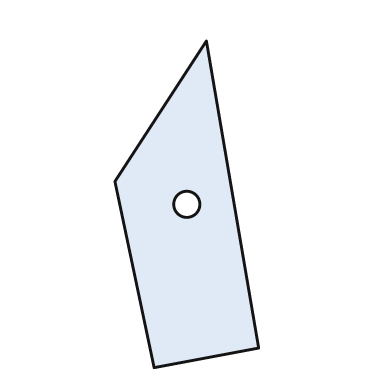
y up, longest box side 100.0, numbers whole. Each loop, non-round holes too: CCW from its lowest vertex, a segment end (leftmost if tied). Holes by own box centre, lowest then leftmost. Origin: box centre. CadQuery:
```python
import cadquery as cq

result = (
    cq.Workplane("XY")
    .moveTo(-10.0, -50.0)
    .lineTo(22.0, -44.0)
    .lineTo(6.0, 50.0)
    .lineTo(-22.0, 7.0)
    .close()
    .moveTo(0.0, 0.0)
    .circle(4.0)
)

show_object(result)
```